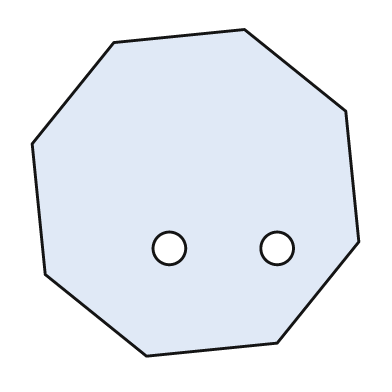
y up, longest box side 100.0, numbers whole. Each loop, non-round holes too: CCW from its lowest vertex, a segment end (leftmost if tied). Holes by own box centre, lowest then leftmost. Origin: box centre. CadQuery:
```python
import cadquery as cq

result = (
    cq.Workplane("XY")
    .moveTo(-15.0, -50.0)
    .lineTo(25.0, -46.0)
    .lineTo(50.0, -15.0)
    .lineTo(46.0, 25.0)
    .lineTo(15.0, 50.0)
    .lineTo(-25.0, 46.0)
    .lineTo(-50.0, 15.0)
    .lineTo(-46.0, -25.0)
    .close()
    .moveTo(-8.0, -17.0)
    .circle(5.0)
    .moveTo(25.0, -17.0)
    .circle(5.0)
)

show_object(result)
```